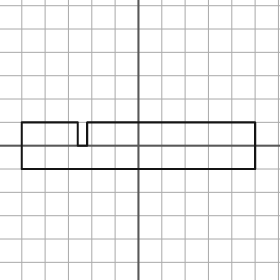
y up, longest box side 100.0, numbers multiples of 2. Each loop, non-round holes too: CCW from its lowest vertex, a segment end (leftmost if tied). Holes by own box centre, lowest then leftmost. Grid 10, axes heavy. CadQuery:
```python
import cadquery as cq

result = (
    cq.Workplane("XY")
    .moveTo(-50.0, -10.0)
    .lineTo(50.0, -10.0)
    .lineTo(50.0, 10.0)
    .lineTo(-22.0, 10.0)
    .lineTo(-22.0, 0.0)
    .lineTo(-26.0, 0.0)
    .lineTo(-26.0, 10.0)
    .lineTo(-50.0, 10.0)
    .close()
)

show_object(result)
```